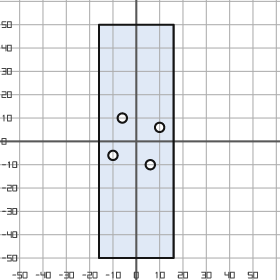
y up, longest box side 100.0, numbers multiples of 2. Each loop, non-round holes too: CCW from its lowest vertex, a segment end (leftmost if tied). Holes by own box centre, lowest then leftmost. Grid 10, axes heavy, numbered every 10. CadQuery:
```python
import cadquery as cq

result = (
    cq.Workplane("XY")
    .moveTo(-16.0, -50.0)
    .lineTo(16.0, -50.0)
    .lineTo(16.0, 50.0)
    .lineTo(-16.0, 50.0)
    .close()
    .moveTo(6.0, -10.0)
    .circle(2.0)
    .moveTo(-10.0, -6.0)
    .circle(2.0)
    .moveTo(10.0, 6.0)
    .circle(2.0)
    .moveTo(-6.0, 10.0)
    .circle(2.0)
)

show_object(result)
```